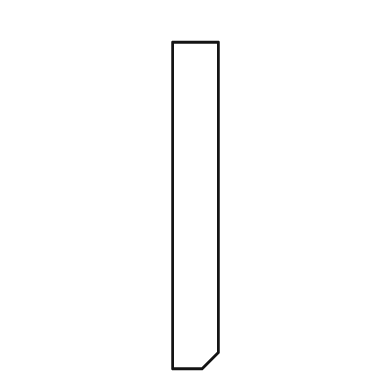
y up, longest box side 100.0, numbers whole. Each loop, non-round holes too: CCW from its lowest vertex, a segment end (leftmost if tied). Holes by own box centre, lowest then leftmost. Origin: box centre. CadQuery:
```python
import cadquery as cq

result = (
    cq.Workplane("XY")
    .moveTo(-7.0, -50.0)
    .lineTo(2.0, -50.0)
    .lineTo(7.0, -45.0)
    .lineTo(7.0, 50.0)
    .lineTo(-7.0, 50.0)
    .close()
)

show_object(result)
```